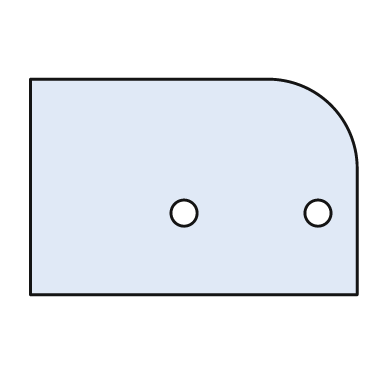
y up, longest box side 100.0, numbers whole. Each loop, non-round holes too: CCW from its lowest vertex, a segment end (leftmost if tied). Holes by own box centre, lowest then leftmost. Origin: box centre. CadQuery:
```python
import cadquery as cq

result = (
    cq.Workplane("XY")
    .moveTo(-50.0, -33.0)
    .lineTo(50.0, -33.0)
    .lineTo(50.0, 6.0)
    .threePointArc((42.0, 25.0), (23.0, 33.0))
    .lineTo(-50.0, 33.0)
    .close()
    .moveTo(-3.0, -8.0)
    .circle(4.0)
    .moveTo(38.0, -8.0)
    .circle(4.0)
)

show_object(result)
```